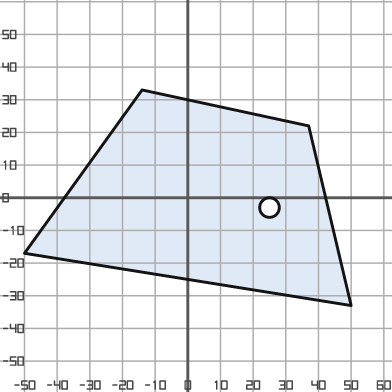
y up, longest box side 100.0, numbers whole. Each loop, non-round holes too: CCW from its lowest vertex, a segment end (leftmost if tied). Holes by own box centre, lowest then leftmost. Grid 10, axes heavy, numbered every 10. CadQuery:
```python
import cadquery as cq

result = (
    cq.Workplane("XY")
    .moveTo(50.0, -33.0)
    .lineTo(37.0, 22.0)
    .lineTo(-14.0, 33.0)
    .lineTo(-50.0, -17.0)
    .close()
    .moveTo(25.0, -3.0)
    .circle(3.0)
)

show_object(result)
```